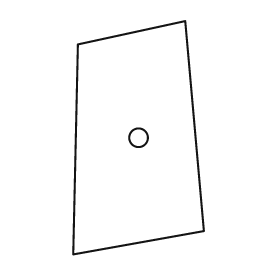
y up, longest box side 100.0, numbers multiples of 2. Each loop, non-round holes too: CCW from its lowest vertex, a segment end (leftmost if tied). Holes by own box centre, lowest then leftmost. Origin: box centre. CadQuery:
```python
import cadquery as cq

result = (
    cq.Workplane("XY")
    .moveTo(-28.0, -50.0)
    .lineTo(28.0, -40.0)
    .lineTo(20.0, 50.0)
    .lineTo(-26.0, 40.0)
    .close()
    .moveTo(0.0, 0.0)
    .circle(4.0)
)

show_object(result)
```